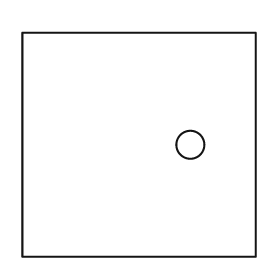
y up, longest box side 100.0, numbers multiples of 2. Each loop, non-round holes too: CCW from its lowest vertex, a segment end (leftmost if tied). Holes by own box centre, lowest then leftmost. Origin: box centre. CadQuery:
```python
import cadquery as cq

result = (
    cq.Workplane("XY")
    .moveTo(-50.0, -48.0)
    .lineTo(50.0, -48.0)
    .lineTo(50.0, 48.0)
    .lineTo(-50.0, 48.0)
    .close()
    .moveTo(22.0, 0.0)
    .circle(6.0)
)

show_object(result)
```